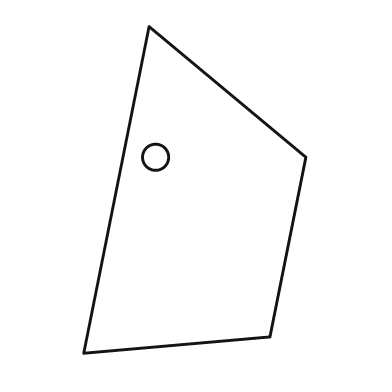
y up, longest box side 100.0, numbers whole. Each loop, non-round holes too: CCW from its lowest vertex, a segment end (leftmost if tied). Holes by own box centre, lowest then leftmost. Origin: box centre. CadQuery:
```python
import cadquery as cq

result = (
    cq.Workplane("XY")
    .moveTo(-34.0, -50.0)
    .lineTo(23.0, -45.0)
    .lineTo(34.0, 10.0)
    .lineTo(-14.0, 50.0)
    .close()
    .moveTo(-12.0, 10.0)
    .circle(4.0)
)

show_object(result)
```